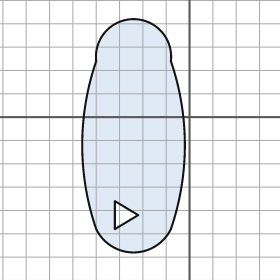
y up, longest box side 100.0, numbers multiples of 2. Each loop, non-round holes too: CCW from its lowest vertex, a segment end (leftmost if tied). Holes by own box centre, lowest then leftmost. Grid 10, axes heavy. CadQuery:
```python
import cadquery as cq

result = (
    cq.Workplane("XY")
    .moveTo(-40.0, -48.0)
    .threePointArc((-24.0, -58.0), (-8.0, -48.0))
    .threePointArc((-2.0, -12.0), (-8.0, 24.0))
    .threePointArc((-24.0, 42.0), (-40.0, 24.0))
    .threePointArc((-46.0, -12.0), (-40.0, -48.0))
    .close()
    .moveTo(-32.0, -48.0)
    .lineTo(-22.0, -42.0)
    .lineTo(-32.0, -36.0)
    .close()
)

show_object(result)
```